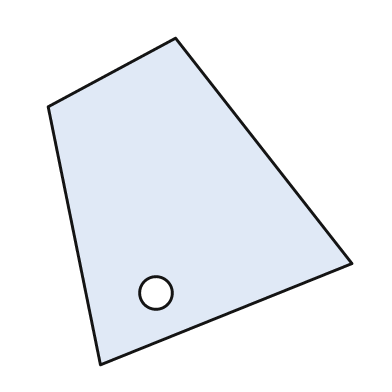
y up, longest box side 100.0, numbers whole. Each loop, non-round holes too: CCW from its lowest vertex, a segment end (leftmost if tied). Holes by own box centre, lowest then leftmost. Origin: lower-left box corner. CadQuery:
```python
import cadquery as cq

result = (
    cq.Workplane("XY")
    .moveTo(16.0, 0.0)
    .lineTo(93.0, 31.0)
    .lineTo(39.0, 100.0)
    .lineTo(0.0, 79.0)
    .close()
    .moveTo(33.0, 22.0)
    .circle(5.0)
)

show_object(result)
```